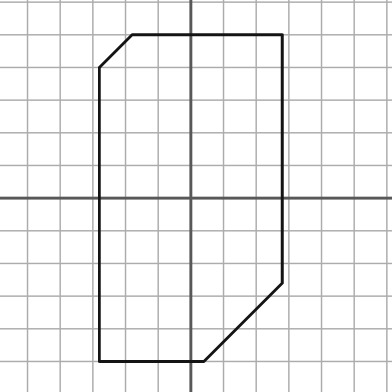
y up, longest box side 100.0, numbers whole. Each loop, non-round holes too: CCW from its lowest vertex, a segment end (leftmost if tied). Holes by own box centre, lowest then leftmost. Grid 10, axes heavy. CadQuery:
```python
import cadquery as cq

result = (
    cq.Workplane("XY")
    .moveTo(-28.0, -50.0)
    .lineTo(4.0, -50.0)
    .lineTo(28.0, -26.0)
    .lineTo(28.0, 50.0)
    .lineTo(-18.0, 50.0)
    .lineTo(-28.0, 40.0)
    .close()
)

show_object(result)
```